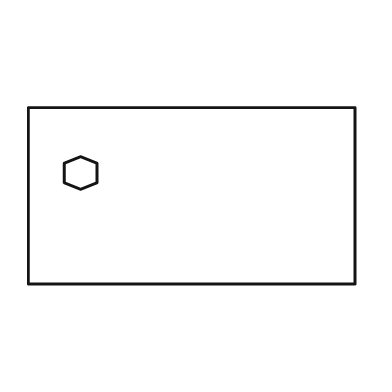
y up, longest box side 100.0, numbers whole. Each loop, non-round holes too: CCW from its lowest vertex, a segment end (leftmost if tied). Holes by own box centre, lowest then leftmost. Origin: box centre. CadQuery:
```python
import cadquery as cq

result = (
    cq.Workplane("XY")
    .moveTo(-50.0, -27.0)
    .lineTo(50.0, -27.0)
    .lineTo(50.0, 27.0)
    .lineTo(-50.0, 27.0)
    .close()
    .moveTo(-34.0, 2.0)
    .lineTo(-29.0, 4.0)
    .lineTo(-29.0, 10.0)
    .lineTo(-34.0, 12.0)
    .lineTo(-39.0, 10.0)
    .lineTo(-39.0, 4.0)
    .close()
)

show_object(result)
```